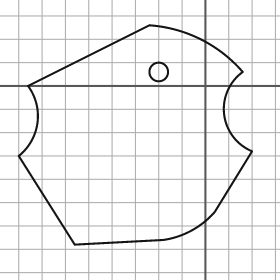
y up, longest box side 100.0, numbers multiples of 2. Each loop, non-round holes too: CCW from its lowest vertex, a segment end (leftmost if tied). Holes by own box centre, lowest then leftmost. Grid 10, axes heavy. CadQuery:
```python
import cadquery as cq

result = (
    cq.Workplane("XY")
    .moveTo(-56.0, -68.0)
    .lineTo(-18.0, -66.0)
    .threePointArc((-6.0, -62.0), (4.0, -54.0))
    .lineTo(20.0, -28.0)
    .threePointArc((8.0, -12.0), (16.0, 6.0))
    .threePointArc((-2.0, 20.0), (-24.0, 26.0))
    .lineTo(-76.0, 0.0)
    .threePointArc((-72.0, -16.0), (-80.0, -30.0))
    .close()
    .moveTo(-20.0, 6.0)
    .circle(4.0)
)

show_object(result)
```